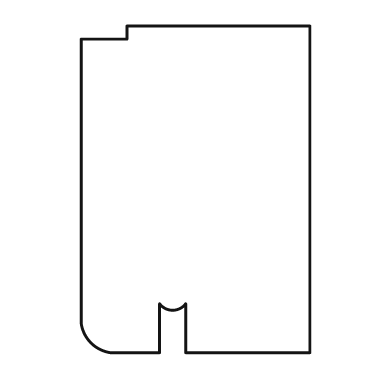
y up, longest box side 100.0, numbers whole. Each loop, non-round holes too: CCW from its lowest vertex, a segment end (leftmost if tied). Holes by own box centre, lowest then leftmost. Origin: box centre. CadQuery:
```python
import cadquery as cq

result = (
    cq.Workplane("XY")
    .moveTo(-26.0, -50.0)
    .lineTo(-11.0, -50.0)
    .lineTo(-11.0, -35.0)
    .threePointArc((-7.0, -37.0), (-3.0, -35.0))
    .lineTo(-3.0, -50.0)
    .lineTo(35.0, -50.0)
    .lineTo(35.0, 50.0)
    .lineTo(-21.0, 50.0)
    .lineTo(-21.0, 46.0)
    .lineTo(-35.0, 46.0)
    .lineTo(-35.0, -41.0)
    .threePointArc((-32.0, -47.0), (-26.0, -50.0))
    .close()
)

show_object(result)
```